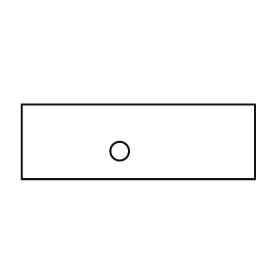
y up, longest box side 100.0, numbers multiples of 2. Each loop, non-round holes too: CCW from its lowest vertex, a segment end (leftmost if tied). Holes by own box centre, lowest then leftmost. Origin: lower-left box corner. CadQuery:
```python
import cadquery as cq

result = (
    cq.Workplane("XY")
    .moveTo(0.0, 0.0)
    .lineTo(100.0, 0.0)
    .lineTo(100.0, 32.0)
    .lineTo(0.0, 32.0)
    .close()
    .moveTo(42.0, 12.0)
    .circle(4.0)
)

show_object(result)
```